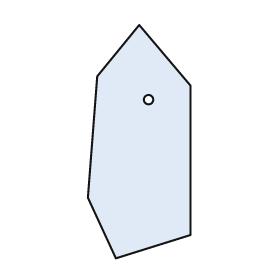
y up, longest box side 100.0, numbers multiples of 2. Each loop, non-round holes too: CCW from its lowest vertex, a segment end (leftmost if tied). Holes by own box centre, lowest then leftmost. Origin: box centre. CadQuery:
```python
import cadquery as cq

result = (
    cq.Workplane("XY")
    .moveTo(-10.0, -50.0)
    .lineTo(22.0, -40.0)
    .lineTo(22.0, 24.0)
    .lineTo(0.0, 50.0)
    .lineTo(-18.0, 28.0)
    .lineTo(-22.0, -24.0)
    .close()
    .moveTo(4.0, 18.0)
    .circle(2.0)
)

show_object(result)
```